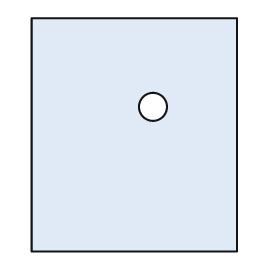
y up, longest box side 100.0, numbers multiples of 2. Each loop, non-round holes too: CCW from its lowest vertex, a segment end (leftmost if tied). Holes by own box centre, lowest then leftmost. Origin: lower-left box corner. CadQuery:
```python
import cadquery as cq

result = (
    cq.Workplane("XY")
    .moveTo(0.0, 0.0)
    .lineTo(88.0, 0.0)
    .lineTo(88.0, 100.0)
    .lineTo(0.0, 100.0)
    .close()
    .moveTo(52.0, 62.0)
    .circle(6.0)
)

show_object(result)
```